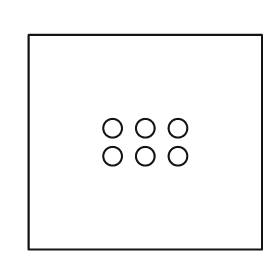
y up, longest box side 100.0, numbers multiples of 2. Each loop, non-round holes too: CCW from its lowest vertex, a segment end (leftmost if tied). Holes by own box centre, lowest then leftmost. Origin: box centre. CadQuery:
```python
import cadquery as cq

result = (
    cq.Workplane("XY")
    .moveTo(-50.0, -46.0)
    .lineTo(50.0, -46.0)
    .lineTo(50.0, 46.0)
    .lineTo(-50.0, 46.0)
    .close()
    .moveTo(-14.0, -6.0)
    .circle(4.0)
    .moveTo(0.0, -6.0)
    .circle(4.0)
    .moveTo(14.0, -6.0)
    .circle(4.0)
    .moveTo(-14.0, 6.0)
    .circle(4.0)
    .moveTo(0.0, 6.0)
    .circle(4.0)
    .moveTo(14.0, 6.0)
    .circle(4.0)
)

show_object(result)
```